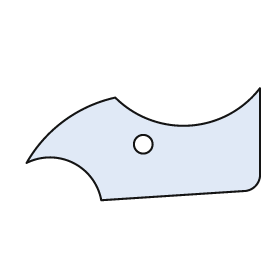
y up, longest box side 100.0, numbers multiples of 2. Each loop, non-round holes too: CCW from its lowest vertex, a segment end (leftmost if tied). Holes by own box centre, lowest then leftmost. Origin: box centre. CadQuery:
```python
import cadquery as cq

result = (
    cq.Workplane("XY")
    .moveTo(-18.0, -24.0)
    .lineTo(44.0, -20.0)
    .threePointArc((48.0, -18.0), (50.0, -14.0))
    .lineTo(50.0, 24.0)
    .threePointArc((20.0, 8.0), (-12.0, 20.0))
    .threePointArc((-34.0, 10.0), (-50.0, -8.0))
    .threePointArc((-30.0, -8.0), (-18.0, -24.0))
    .close()
    .moveTo(0.0, 0.0)
    .circle(4.0)
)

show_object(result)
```